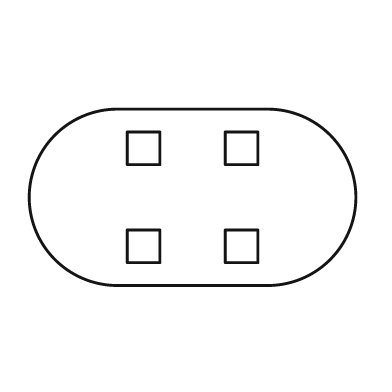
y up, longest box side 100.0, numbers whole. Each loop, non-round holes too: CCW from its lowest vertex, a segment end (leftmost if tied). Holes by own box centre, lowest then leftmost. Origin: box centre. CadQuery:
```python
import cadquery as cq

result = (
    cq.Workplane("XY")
    .moveTo(-23.0, -27.0)
    .lineTo(23.0, -27.0)
    .threePointArc((50.0, 0.0), (23.0, 27.0))
    .lineTo(-23.0, 27.0)
    .threePointArc((-50.0, 0.0), (-23.0, -27.0))
    .close()
    .moveTo(-20.0, -20.0)
    .lineTo(-10.0, -20.0)
    .lineTo(-10.0, -10.0)
    .lineTo(-20.0, -10.0)
    .close()
    .moveTo(10.0, -20.0)
    .lineTo(20.0, -20.0)
    .lineTo(20.0, -10.0)
    .lineTo(10.0, -10.0)
    .close()
    .moveTo(-20.0, 10.0)
    .lineTo(-10.0, 10.0)
    .lineTo(-10.0, 20.0)
    .lineTo(-20.0, 20.0)
    .close()
    .moveTo(10.0, 10.0)
    .lineTo(20.0, 10.0)
    .lineTo(20.0, 20.0)
    .lineTo(10.0, 20.0)
    .close()
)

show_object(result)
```